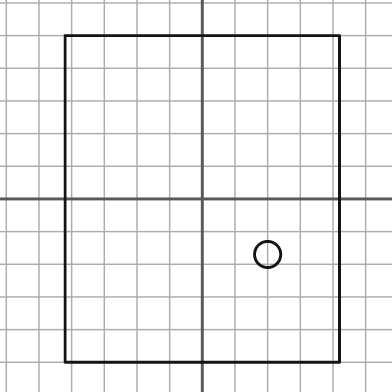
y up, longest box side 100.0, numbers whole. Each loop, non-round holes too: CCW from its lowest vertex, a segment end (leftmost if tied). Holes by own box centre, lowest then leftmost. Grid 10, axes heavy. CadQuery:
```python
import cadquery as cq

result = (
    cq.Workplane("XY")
    .moveTo(-42.0, -50.0)
    .lineTo(42.0, -50.0)
    .lineTo(42.0, 50.0)
    .lineTo(-42.0, 50.0)
    .close()
    .moveTo(20.0, -17.0)
    .circle(4.0)
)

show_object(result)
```